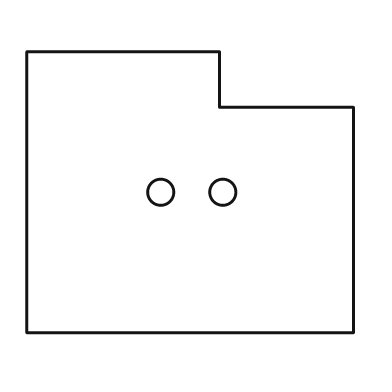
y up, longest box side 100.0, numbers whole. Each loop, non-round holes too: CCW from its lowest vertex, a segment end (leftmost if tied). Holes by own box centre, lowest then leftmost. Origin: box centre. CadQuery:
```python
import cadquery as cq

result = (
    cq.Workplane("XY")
    .moveTo(-50.0, -43.0)
    .lineTo(50.0, -43.0)
    .lineTo(50.0, 26.0)
    .lineTo(9.0, 26.0)
    .lineTo(9.0, 43.0)
    .lineTo(-50.0, 43.0)
    .close()
    .moveTo(-9.0, 0.0)
    .circle(4.0)
    .moveTo(10.0, 0.0)
    .circle(4.0)
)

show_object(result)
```